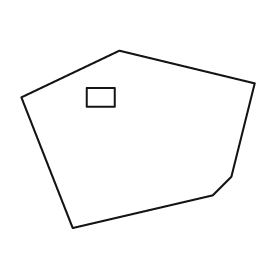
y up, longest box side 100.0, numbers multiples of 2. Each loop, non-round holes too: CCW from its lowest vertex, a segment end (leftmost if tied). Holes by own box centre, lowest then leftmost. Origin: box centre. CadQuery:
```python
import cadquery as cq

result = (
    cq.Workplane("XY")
    .moveTo(-28.0, -38.0)
    .lineTo(32.0, -24.0)
    .lineTo(40.0, -16.0)
    .lineTo(50.0, 24.0)
    .lineTo(-8.0, 38.0)
    .lineTo(-50.0, 18.0)
    .close()
    .moveTo(-22.0, 14.0)
    .lineTo(-10.0, 14.0)
    .lineTo(-10.0, 22.0)
    .lineTo(-22.0, 22.0)
    .close()
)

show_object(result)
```